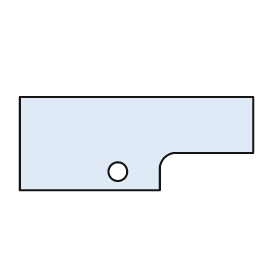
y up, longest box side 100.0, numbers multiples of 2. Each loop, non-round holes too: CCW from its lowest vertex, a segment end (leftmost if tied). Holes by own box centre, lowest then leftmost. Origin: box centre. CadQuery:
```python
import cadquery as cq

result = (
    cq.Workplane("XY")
    .moveTo(-50.0, -20.0)
    .lineTo(10.0, -20.0)
    .lineTo(10.0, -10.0)
    .threePointArc((12.0, -6.0), (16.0, -4.0))
    .lineTo(50.0, -4.0)
    .lineTo(50.0, 20.0)
    .lineTo(-50.0, 20.0)
    .close()
    .moveTo(-8.0, -12.0)
    .circle(4.0)
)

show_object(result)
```